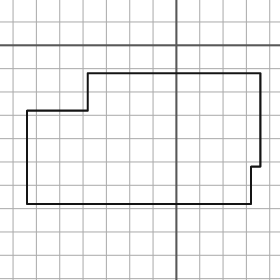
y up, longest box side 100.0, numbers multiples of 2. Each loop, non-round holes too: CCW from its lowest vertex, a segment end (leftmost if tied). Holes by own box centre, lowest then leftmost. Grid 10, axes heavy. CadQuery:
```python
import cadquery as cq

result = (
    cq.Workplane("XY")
    .moveTo(-64.0, -68.0)
    .lineTo(32.0, -68.0)
    .lineTo(32.0, -52.0)
    .lineTo(36.0, -52.0)
    .lineTo(36.0, -12.0)
    .lineTo(-38.0, -12.0)
    .lineTo(-38.0, -28.0)
    .lineTo(-64.0, -28.0)
    .close()
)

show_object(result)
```